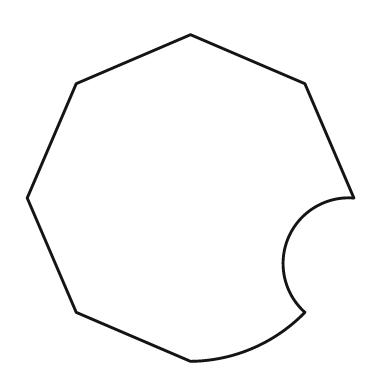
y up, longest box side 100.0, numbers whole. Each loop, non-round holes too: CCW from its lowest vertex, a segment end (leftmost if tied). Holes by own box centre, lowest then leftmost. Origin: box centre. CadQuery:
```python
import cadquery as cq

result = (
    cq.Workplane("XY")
    .moveTo(0.0, -50.0)
    .threePointArc((19.0, -46.0), (35.0, -35.0))
    .threePointArc((30.0, -12.0), (50.0, 0.0))
    .lineTo(35.0, 35.0)
    .lineTo(0.0, 50.0)
    .lineTo(-35.0, 35.0)
    .lineTo(-50.0, 0.0)
    .lineTo(-35.0, -35.0)
    .close()
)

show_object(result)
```